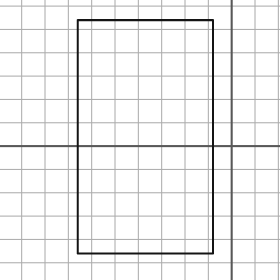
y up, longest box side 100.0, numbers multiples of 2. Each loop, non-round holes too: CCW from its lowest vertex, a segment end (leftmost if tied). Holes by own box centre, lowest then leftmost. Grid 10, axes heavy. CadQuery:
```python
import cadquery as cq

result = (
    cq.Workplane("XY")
    .moveTo(-66.0, -46.0)
    .lineTo(-8.0, -46.0)
    .lineTo(-8.0, 54.0)
    .lineTo(-66.0, 54.0)
    .close()
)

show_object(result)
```